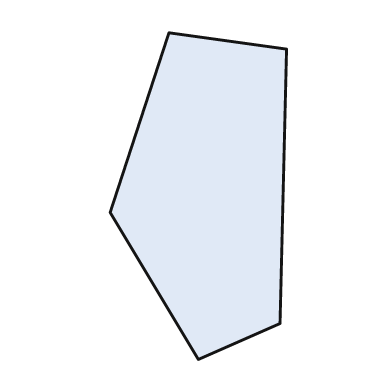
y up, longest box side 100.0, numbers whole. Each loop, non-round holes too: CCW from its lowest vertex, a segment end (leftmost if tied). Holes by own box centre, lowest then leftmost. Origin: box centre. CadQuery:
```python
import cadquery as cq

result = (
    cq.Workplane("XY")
    .moveTo(0.0, -50.0)
    .lineTo(25.0, -39.0)
    .lineTo(27.0, 45.0)
    .lineTo(-9.0, 50.0)
    .lineTo(-27.0, -5.0)
    .close()
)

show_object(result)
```